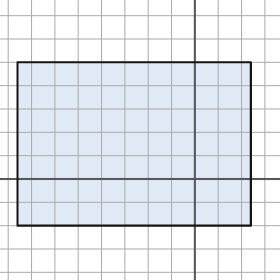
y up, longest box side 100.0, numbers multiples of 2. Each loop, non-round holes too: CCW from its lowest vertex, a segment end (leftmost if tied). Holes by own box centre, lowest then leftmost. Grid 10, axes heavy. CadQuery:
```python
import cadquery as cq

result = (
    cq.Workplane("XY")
    .moveTo(-76.0, -20.0)
    .lineTo(24.0, -20.0)
    .lineTo(24.0, 50.0)
    .lineTo(-76.0, 50.0)
    .close()
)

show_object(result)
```